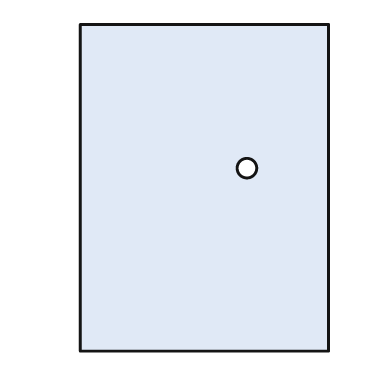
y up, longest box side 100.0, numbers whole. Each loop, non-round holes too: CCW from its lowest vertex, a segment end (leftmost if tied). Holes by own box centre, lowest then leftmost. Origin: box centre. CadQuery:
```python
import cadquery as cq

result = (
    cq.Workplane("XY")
    .moveTo(-38.0, -50.0)
    .lineTo(38.0, -50.0)
    .lineTo(38.0, 50.0)
    .lineTo(-38.0, 50.0)
    .close()
    .moveTo(13.0, 6.0)
    .circle(3.0)
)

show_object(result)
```